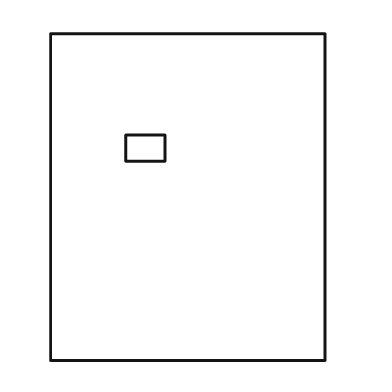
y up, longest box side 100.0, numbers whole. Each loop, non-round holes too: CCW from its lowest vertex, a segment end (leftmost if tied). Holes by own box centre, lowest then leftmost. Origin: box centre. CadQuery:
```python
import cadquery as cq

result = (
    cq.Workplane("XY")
    .moveTo(-42.0, -50.0)
    .lineTo(42.0, -50.0)
    .lineTo(42.0, 50.0)
    .lineTo(-42.0, 50.0)
    .close()
    .moveTo(-19.0, 11.0)
    .lineTo(-7.0, 11.0)
    .lineTo(-7.0, 19.0)
    .lineTo(-19.0, 19.0)
    .close()
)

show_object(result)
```